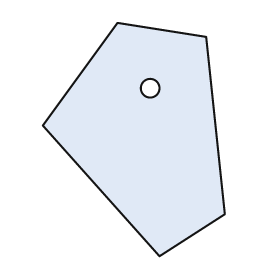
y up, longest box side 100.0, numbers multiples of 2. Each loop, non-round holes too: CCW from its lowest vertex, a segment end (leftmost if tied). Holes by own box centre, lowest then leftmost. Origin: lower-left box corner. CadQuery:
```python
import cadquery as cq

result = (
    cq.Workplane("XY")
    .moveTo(50.0, 0.0)
    .lineTo(78.0, 18.0)
    .lineTo(70.0, 94.0)
    .lineTo(32.0, 100.0)
    .lineTo(0.0, 56.0)
    .close()
    .moveTo(46.0, 72.0)
    .circle(4.0)
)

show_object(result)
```